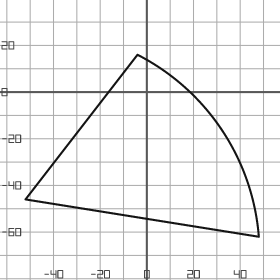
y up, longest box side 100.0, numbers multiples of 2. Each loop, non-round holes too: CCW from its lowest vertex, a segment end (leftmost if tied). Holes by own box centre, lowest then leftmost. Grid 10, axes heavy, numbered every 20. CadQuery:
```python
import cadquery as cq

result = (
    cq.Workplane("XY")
    .moveTo(48.0, -62.0)
    .threePointArc((32.0, -16.0), (-4.0, 16.0))
    .lineTo(-52.0, -46.0)
    .close()
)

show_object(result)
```